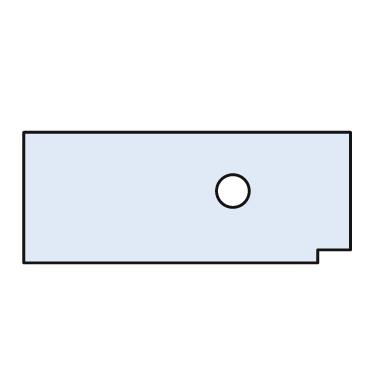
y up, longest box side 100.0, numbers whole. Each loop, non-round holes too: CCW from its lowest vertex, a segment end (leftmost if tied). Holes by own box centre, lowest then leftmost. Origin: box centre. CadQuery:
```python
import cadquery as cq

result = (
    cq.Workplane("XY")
    .moveTo(-50.0, -20.0)
    .lineTo(40.0, -20.0)
    .lineTo(40.0, -16.0)
    .lineTo(50.0, -16.0)
    .lineTo(50.0, 20.0)
    .lineTo(-50.0, 20.0)
    .close()
    .moveTo(14.0, 2.0)
    .circle(5.0)
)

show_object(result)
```